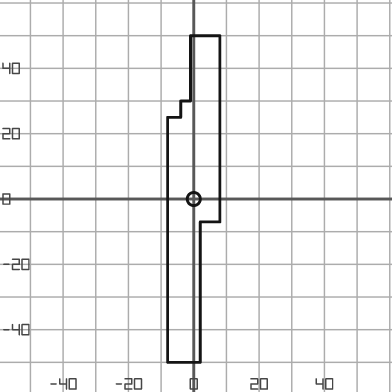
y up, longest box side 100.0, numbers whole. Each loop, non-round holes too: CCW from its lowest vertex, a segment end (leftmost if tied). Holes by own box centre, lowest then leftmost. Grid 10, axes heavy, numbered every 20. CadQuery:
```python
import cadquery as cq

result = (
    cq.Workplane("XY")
    .moveTo(-8.0, -50.0)
    .lineTo(2.0, -50.0)
    .lineTo(2.0, -7.0)
    .lineTo(8.0, -7.0)
    .lineTo(8.0, 50.0)
    .lineTo(-1.0, 50.0)
    .lineTo(-1.0, 30.0)
    .lineTo(-4.0, 30.0)
    .lineTo(-4.0, 25.0)
    .lineTo(-8.0, 25.0)
    .close()
    .moveTo(0.0, 0.0)
    .circle(2.0)
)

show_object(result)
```